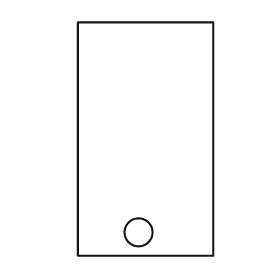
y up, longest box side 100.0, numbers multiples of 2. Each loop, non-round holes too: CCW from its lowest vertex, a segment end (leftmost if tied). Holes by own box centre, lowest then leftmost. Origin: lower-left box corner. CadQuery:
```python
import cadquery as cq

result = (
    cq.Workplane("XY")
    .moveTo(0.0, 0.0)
    .lineTo(58.0, 0.0)
    .lineTo(58.0, 100.0)
    .lineTo(0.0, 100.0)
    .close()
    .moveTo(26.0, 10.0)
    .circle(6.0)
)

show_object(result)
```